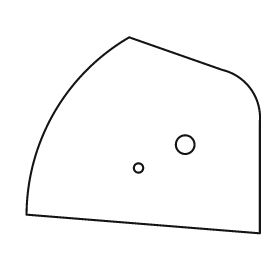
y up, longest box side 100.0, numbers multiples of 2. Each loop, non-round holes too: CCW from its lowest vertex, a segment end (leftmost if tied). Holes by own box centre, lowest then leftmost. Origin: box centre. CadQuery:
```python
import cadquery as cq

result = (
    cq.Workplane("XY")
    .moveTo(50.0, -42.0)
    .lineTo(50.0, 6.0)
    .threePointArc((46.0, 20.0), (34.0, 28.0))
    .lineTo(-6.0, 42.0)
    .threePointArc((-38.0, 10.0), (-50.0, -34.0))
    .close()
    .moveTo(-2.0, -14.0)
    .circle(2.0)
    .moveTo(18.0, -4.0)
    .circle(4.0)
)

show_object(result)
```